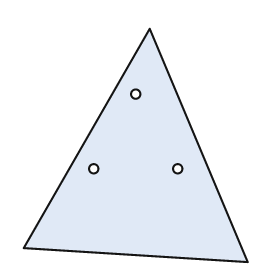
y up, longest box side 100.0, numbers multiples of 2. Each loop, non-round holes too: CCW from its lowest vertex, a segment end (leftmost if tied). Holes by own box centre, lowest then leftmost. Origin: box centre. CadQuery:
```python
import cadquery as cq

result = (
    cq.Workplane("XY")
    .moveTo(48.0, -50.0)
    .lineTo(6.0, 50.0)
    .lineTo(-48.0, -44.0)
    .close()
    .moveTo(-18.0, -10.0)
    .circle(2.0)
    .moveTo(18.0, -10.0)
    .circle(2.0)
    .moveTo(0.0, 22.0)
    .circle(2.0)
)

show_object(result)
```